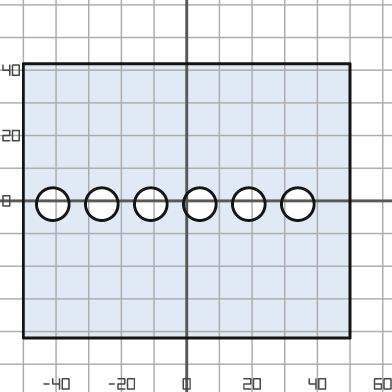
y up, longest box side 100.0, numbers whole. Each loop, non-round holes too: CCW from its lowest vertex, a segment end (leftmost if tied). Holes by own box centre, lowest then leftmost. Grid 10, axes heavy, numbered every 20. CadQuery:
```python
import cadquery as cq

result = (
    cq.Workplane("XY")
    .moveTo(-50.0, -42.0)
    .lineTo(50.0, -42.0)
    .lineTo(50.0, 42.0)
    .lineTo(-50.0, 42.0)
    .close()
    .moveTo(-41.0, -1.0)
    .circle(5.0)
    .moveTo(-26.0, -1.0)
    .circle(5.0)
    .moveTo(-11.0, -1.0)
    .circle(5.0)
    .moveTo(4.0, -1.0)
    .circle(5.0)
    .moveTo(19.0, -1.0)
    .circle(5.0)
    .moveTo(34.0, -1.0)
    .circle(5.0)
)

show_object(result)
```